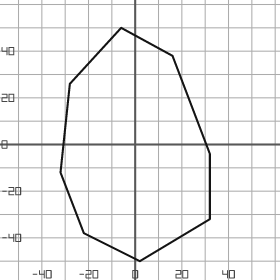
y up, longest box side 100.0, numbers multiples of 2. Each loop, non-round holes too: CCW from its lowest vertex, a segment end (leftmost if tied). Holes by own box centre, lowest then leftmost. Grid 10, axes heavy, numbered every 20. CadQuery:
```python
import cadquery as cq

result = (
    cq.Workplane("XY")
    .moveTo(2.0, -50.0)
    .lineTo(32.0, -32.0)
    .lineTo(32.0, -4.0)
    .lineTo(16.0, 38.0)
    .lineTo(-6.0, 50.0)
    .lineTo(-28.0, 26.0)
    .lineTo(-32.0, -12.0)
    .lineTo(-22.0, -38.0)
    .close()
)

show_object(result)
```